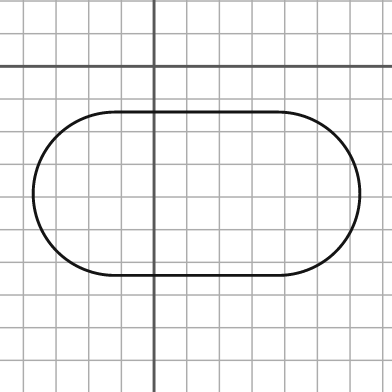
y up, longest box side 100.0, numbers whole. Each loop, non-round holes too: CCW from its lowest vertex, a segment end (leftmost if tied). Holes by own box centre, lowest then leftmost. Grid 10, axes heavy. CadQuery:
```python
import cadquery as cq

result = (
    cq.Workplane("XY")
    .moveTo(-12.0, -64.0)
    .lineTo(38.0, -64.0)
    .threePointArc((63.0, -39.0), (38.0, -14.0))
    .lineTo(-12.0, -14.0)
    .threePointArc((-37.0, -39.0), (-12.0, -64.0))
    .close()
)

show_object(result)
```